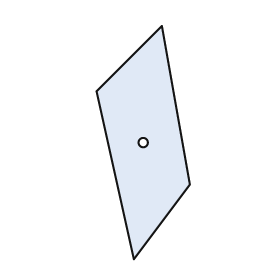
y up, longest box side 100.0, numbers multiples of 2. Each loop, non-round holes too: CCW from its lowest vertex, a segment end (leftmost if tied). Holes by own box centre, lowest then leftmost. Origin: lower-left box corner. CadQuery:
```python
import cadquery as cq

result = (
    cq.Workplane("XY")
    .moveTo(16.0, 0.0)
    .lineTo(40.0, 32.0)
    .lineTo(28.0, 100.0)
    .lineTo(0.0, 72.0)
    .close()
    .moveTo(20.0, 50.0)
    .circle(2.0)
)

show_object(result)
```